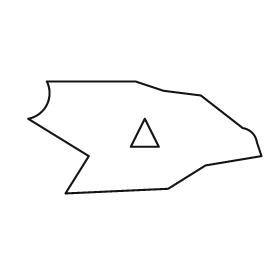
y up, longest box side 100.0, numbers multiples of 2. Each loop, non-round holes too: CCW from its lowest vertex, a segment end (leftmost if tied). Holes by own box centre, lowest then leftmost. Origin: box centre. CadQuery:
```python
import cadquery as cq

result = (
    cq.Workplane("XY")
    .moveTo(-34.0, -24.0)
    .lineTo(10.0, -22.0)
    .lineTo(26.0, -12.0)
    .lineTo(50.0, -8.0)
    .lineTo(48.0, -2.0)
    .threePointArc((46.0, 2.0), (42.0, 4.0))
    .lineTo(24.0, 18.0)
    .lineTo(8.0, 20.0)
    .lineTo(-4.0, 24.0)
    .lineTo(-42.0, 24.0)
    .threePointArc((-42.0, 14.0), (-50.0, 8.0))
    .lineTo(-24.0, -8.0)
    .close()
    .moveTo(-6.0, -4.0)
    .lineTo(6.0, -4.0)
    .lineTo(0.0, 8.0)
    .close()
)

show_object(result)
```